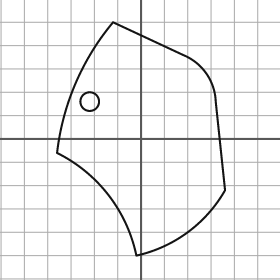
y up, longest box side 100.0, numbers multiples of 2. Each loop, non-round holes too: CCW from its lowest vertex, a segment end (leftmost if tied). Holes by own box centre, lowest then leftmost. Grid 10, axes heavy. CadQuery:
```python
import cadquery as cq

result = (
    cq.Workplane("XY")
    .moveTo(-2.0, -50.0)
    .threePointArc((20.0, -40.0), (36.0, -22.0))
    .lineTo(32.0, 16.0)
    .threePointArc((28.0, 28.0), (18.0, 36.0))
    .lineTo(-12.0, 50.0)
    .threePointArc((-28.0, 24.0), (-36.0, -6.0))
    .threePointArc((-14.0, -24.0), (-2.0, -50.0))
    .close()
    .moveTo(-22.0, 16.0)
    .circle(4.0)
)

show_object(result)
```